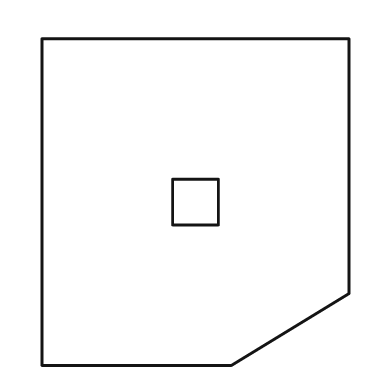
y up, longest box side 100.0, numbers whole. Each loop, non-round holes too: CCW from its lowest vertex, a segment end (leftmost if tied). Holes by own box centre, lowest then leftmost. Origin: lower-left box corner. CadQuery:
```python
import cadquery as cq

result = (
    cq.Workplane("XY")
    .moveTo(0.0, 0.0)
    .lineTo(58.0, 0.0)
    .lineTo(94.0, 22.0)
    .lineTo(94.0, 100.0)
    .lineTo(0.0, 100.0)
    .close()
    .moveTo(40.0, 43.0)
    .lineTo(54.0, 43.0)
    .lineTo(54.0, 57.0)
    .lineTo(40.0, 57.0)
    .close()
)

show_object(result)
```